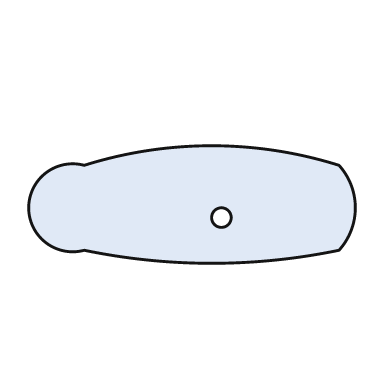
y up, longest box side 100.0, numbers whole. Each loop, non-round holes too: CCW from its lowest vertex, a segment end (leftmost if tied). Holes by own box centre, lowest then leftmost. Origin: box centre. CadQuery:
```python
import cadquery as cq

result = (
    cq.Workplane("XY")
    .moveTo(-33.0, -14.0)
    .threePointArc((6.0, -18.0), (45.0, -14.0))
    .threePointArc((50.0, -1.0), (45.0, 12.0))
    .threePointArc((6.0, 18.0), (-33.0, 12.0))
    .threePointArc((-50.0, -1.0), (-33.0, -14.0))
    .close()
    .moveTo(9.0, -4.0)
    .circle(3.0)
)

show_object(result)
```